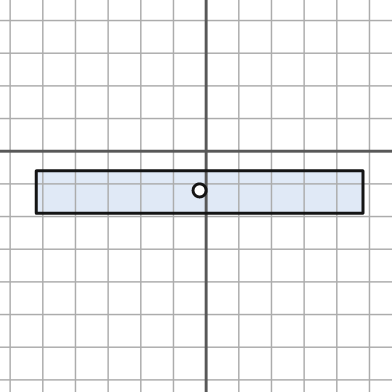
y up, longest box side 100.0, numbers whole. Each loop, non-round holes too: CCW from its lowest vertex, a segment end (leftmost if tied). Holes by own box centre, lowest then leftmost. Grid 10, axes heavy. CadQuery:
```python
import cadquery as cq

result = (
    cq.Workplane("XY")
    .moveTo(-52.0, -19.0)
    .lineTo(48.0, -19.0)
    .lineTo(48.0, -6.0)
    .lineTo(-52.0, -6.0)
    .close()
    .moveTo(-2.0, -12.0)
    .circle(2.0)
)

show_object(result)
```